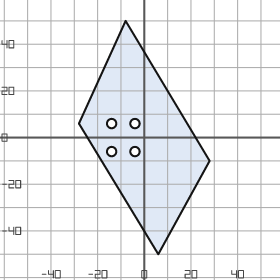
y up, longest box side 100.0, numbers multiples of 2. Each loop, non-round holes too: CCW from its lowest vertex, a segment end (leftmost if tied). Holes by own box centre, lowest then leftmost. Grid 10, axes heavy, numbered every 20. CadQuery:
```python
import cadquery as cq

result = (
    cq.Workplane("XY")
    .moveTo(6.0, -50.0)
    .lineTo(28.0, -10.0)
    .lineTo(-8.0, 50.0)
    .lineTo(-28.0, 6.0)
    .close()
    .moveTo(-14.0, -6.0)
    .circle(2.0)
    .moveTo(-4.0, -6.0)
    .circle(2.0)
    .moveTo(-14.0, 6.0)
    .circle(2.0)
    .moveTo(-4.0, 6.0)
    .circle(2.0)
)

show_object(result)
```